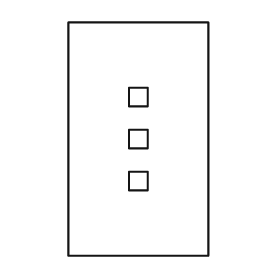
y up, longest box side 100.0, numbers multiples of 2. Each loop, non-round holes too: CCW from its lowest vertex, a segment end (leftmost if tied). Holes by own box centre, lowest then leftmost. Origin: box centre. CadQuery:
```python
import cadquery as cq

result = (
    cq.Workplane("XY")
    .moveTo(-30.0, -50.0)
    .lineTo(30.0, -50.0)
    .lineTo(30.0, 50.0)
    .lineTo(-30.0, 50.0)
    .close()
    .moveTo(-4.0, -22.0)
    .lineTo(4.0, -22.0)
    .lineTo(4.0, -14.0)
    .lineTo(-4.0, -14.0)
    .close()
    .moveTo(-4.0, -4.0)
    .lineTo(4.0, -4.0)
    .lineTo(4.0, 4.0)
    .lineTo(-4.0, 4.0)
    .close()
    .moveTo(-4.0, 14.0)
    .lineTo(4.0, 14.0)
    .lineTo(4.0, 22.0)
    .lineTo(-4.0, 22.0)
    .close()
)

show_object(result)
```